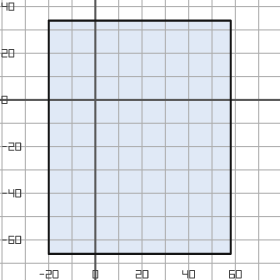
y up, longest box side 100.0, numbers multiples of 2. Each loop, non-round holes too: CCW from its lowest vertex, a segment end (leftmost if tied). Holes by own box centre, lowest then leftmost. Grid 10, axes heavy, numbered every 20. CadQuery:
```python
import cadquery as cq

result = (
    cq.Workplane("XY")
    .moveTo(-20.0, -66.0)
    .lineTo(58.0, -66.0)
    .lineTo(58.0, 34.0)
    .lineTo(-20.0, 34.0)
    .close()
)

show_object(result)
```